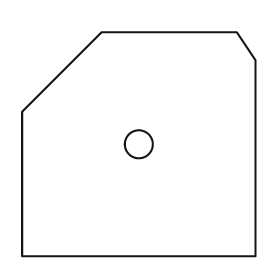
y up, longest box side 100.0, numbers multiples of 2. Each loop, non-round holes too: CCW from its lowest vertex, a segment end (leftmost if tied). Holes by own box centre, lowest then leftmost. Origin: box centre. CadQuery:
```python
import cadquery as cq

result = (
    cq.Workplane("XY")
    .moveTo(-50.0, -48.0)
    .lineTo(50.0, -48.0)
    .lineTo(50.0, 36.0)
    .lineTo(42.0, 48.0)
    .lineTo(-16.0, 48.0)
    .lineTo(-50.0, 14.0)
    .close()
    .moveTo(0.0, 0.0)
    .circle(6.0)
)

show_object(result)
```